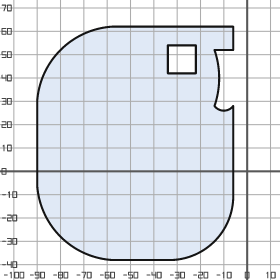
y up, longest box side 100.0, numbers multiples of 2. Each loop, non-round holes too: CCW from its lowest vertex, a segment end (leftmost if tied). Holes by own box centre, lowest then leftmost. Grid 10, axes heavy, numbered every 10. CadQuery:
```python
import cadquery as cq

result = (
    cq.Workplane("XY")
    .moveTo(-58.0, -38.0)
    .lineTo(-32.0, -38.0)
    .threePointArc((-14.0, -30.0), (-6.0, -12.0))
    .lineTo(-6.0, 28.0)
    .threePointArc((-10.0, 26.0), (-14.0, 28.0))
    .threePointArc((-12.0, 40.0), (-14.0, 52.0))
    .lineTo(-6.0, 52.0)
    .lineTo(-6.0, 62.0)
    .lineTo(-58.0, 62.0)
    .threePointArc((-80.0, 52.0), (-90.0, 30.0))
    .lineTo(-90.0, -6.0)
    .threePointArc((-80.0, -28.0), (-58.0, -38.0))
    .close()
    .moveTo(-34.0, 42.0)
    .lineTo(-22.0, 42.0)
    .lineTo(-22.0, 54.0)
    .lineTo(-34.0, 54.0)
    .close()
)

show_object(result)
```